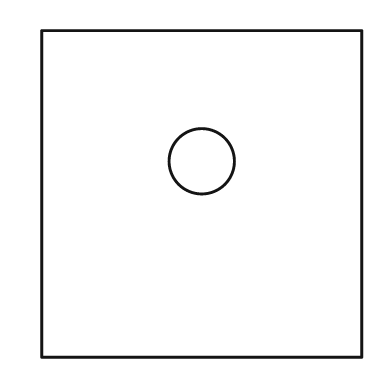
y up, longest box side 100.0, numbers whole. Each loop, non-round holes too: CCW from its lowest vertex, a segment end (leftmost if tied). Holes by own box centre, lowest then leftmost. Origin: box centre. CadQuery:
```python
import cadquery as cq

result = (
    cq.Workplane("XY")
    .moveTo(-49.0, -50.0)
    .lineTo(49.0, -50.0)
    .lineTo(49.0, 50.0)
    .lineTo(-49.0, 50.0)
    .close()
    .moveTo(0.0, 10.0)
    .circle(10.0)
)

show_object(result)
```